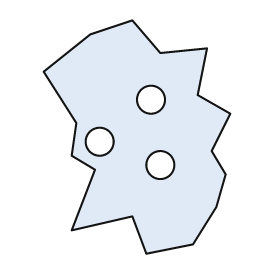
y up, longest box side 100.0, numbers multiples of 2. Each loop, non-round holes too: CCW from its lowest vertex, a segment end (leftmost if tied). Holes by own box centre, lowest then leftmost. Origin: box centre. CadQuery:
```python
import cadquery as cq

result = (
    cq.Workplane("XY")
    .moveTo(4.0, -50.0)
    .lineTo(24.0, -46.0)
    .lineTo(34.0, -30.0)
    .lineTo(38.0, -16.0)
    .lineTo(32.0, -6.0)
    .lineTo(40.0, 10.0)
    .lineTo(26.0, 18.0)
    .lineTo(30.0, 38.0)
    .lineTo(10.0, 36.0)
    .lineTo(-2.0, 50.0)
    .lineTo(-20.0, 44.0)
    .lineTo(-40.0, 28.0)
    .lineTo(-26.0, 6.0)
    .lineTo(-28.0, -8.0)
    .lineTo(-18.0, -14.0)
    .lineTo(-28.0, -40.0)
    .lineTo(-2.0, -34.0)
    .close()
    .moveTo(10.0, -12.0)
    .circle(6.0)
    .moveTo(-16.0, -2.0)
    .circle(6.0)
    .moveTo(6.0, 16.0)
    .circle(6.0)
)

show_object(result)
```